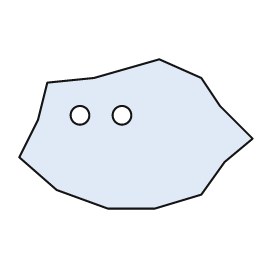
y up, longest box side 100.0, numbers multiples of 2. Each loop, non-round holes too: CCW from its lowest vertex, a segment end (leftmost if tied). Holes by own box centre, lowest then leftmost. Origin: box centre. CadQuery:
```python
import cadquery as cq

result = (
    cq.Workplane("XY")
    .moveTo(-12.0, -32.0)
    .lineTo(8.0, -32.0)
    .lineTo(28.0, -26.0)
    .lineTo(38.0, -12.0)
    .lineTo(50.0, -2.0)
    .lineTo(36.0, 12.0)
    .lineTo(28.0, 24.0)
    .lineTo(10.0, 32.0)
    .lineTo(-18.0, 24.0)
    .lineTo(-38.0, 22.0)
    .lineTo(-42.0, 6.0)
    .lineTo(-50.0, -10.0)
    .lineTo(-34.0, -24.0)
    .close()
    .moveTo(-24.0, 8.0)
    .circle(4.0)
    .moveTo(-6.0, 8.0)
    .circle(4.0)
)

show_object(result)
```